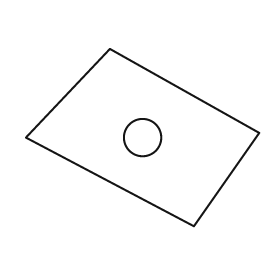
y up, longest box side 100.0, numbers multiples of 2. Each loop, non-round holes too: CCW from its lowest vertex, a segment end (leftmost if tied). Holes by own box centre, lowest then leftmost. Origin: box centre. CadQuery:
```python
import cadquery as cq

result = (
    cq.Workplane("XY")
    .moveTo(22.0, -38.0)
    .lineTo(50.0, 2.0)
    .lineTo(-14.0, 38.0)
    .lineTo(-50.0, 0.0)
    .close()
    .moveTo(0.0, 0.0)
    .circle(8.0)
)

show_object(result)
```